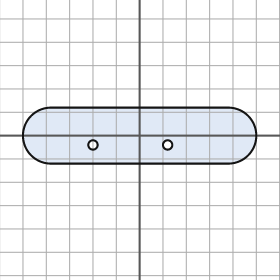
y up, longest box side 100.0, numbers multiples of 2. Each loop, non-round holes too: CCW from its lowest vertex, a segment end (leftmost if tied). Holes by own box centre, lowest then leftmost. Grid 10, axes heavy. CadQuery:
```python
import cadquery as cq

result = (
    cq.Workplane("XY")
    .moveTo(-38.0, -12.0)
    .lineTo(38.0, -12.0)
    .threePointArc((50.0, 0.0), (38.0, 12.0))
    .lineTo(-38.0, 12.0)
    .threePointArc((-50.0, 0.0), (-38.0, -12.0))
    .close()
    .moveTo(-20.0, -4.0)
    .circle(2.0)
    .moveTo(12.0, -4.0)
    .circle(2.0)
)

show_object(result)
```